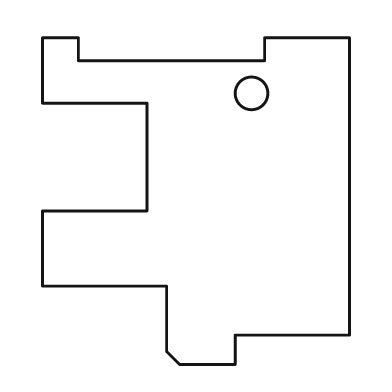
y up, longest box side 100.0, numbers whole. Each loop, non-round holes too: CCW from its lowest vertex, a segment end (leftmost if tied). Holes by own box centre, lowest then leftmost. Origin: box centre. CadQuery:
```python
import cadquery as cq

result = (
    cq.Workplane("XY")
    .moveTo(-5.0, -50.0)
    .lineTo(12.0, -50.0)
    .lineTo(12.0, -41.0)
    .lineTo(47.0, -41.0)
    .lineTo(47.0, 50.0)
    .lineTo(21.0, 50.0)
    .lineTo(21.0, 43.0)
    .lineTo(-36.0, 43.0)
    .lineTo(-36.0, 50.0)
    .lineTo(-47.0, 50.0)
    .lineTo(-47.0, 30.0)
    .lineTo(-15.0, 30.0)
    .lineTo(-15.0, -3.0)
    .lineTo(-47.0, -3.0)
    .lineTo(-47.0, -26.0)
    .lineTo(-9.0, -26.0)
    .lineTo(-9.0, -46.0)
    .close()
    .moveTo(17.0, 33.0)
    .circle(5.0)
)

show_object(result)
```